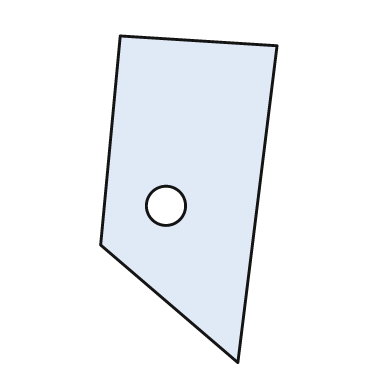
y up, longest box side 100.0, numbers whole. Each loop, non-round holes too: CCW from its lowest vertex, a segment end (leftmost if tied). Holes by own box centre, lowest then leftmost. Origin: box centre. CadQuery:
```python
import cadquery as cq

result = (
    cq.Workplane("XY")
    .moveTo(15.0, -50.0)
    .lineTo(27.0, 47.0)
    .lineTo(-21.0, 50.0)
    .lineTo(-27.0, -14.0)
    .close()
    .moveTo(-7.0, -2.0)
    .circle(6.0)
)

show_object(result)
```